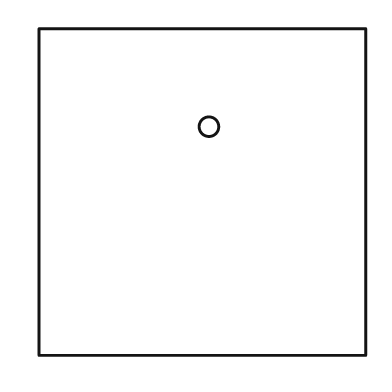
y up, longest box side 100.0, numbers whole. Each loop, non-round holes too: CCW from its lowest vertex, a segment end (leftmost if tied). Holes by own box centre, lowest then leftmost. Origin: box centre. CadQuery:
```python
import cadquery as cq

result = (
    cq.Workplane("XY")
    .moveTo(-50.0, -50.0)
    .lineTo(50.0, -50.0)
    .lineTo(50.0, 50.0)
    .lineTo(-50.0, 50.0)
    .close()
    .moveTo(2.0, 20.0)
    .circle(3.0)
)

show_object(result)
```